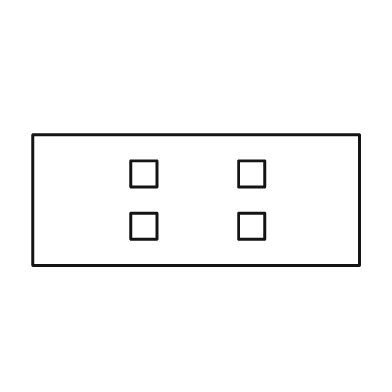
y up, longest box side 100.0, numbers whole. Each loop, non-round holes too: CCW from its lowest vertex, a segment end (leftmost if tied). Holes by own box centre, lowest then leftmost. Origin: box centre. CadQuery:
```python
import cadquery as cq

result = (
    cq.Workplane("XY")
    .moveTo(-50.0, -20.0)
    .lineTo(50.0, -20.0)
    .lineTo(50.0, 20.0)
    .lineTo(-50.0, 20.0)
    .close()
    .moveTo(-20.0, -12.0)
    .lineTo(-12.0, -12.0)
    .lineTo(-12.0, -4.0)
    .lineTo(-20.0, -4.0)
    .close()
    .moveTo(13.0, -12.0)
    .lineTo(21.0, -12.0)
    .lineTo(21.0, -4.0)
    .lineTo(13.0, -4.0)
    .close()
    .moveTo(-20.0, 4.0)
    .lineTo(-12.0, 4.0)
    .lineTo(-12.0, 12.0)
    .lineTo(-20.0, 12.0)
    .close()
    .moveTo(13.0, 4.0)
    .lineTo(21.0, 4.0)
    .lineTo(21.0, 12.0)
    .lineTo(13.0, 12.0)
    .close()
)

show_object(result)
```